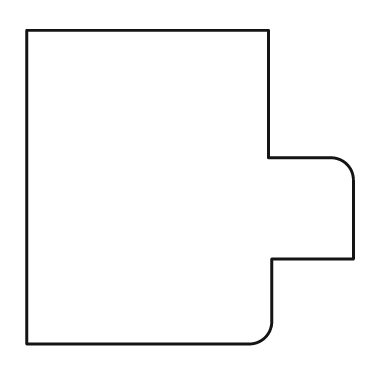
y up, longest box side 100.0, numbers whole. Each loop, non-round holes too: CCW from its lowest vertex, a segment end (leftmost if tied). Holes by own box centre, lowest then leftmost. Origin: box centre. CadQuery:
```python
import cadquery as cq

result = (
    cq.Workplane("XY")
    .moveTo(-50.0, -48.0)
    .lineTo(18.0, -48.0)
    .threePointArc((23.0, -46.0), (25.0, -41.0))
    .lineTo(25.0, -22.0)
    .lineTo(50.0, -22.0)
    .lineTo(50.0, 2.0)
    .threePointArc((48.0, 7.0), (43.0, 9.0))
    .lineTo(24.0, 9.0)
    .lineTo(24.0, 48.0)
    .lineTo(-50.0, 48.0)
    .close()
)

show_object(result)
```